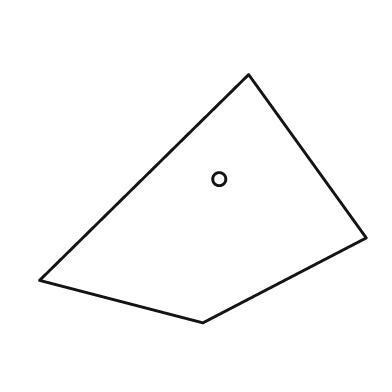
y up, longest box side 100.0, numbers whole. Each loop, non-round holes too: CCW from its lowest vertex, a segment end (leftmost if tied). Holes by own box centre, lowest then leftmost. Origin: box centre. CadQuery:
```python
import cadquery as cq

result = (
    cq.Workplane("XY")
    .moveTo(0.0, -38.0)
    .lineTo(50.0, -12.0)
    .lineTo(14.0, 38.0)
    .lineTo(-50.0, -25.0)
    .close()
    .moveTo(5.0, 6.0)
    .circle(2.0)
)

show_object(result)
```